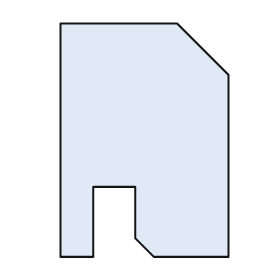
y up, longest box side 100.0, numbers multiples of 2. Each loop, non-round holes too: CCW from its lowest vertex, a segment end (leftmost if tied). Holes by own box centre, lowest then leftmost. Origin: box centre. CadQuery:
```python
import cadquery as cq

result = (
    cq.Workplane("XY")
    .moveTo(-36.0, -50.0)
    .lineTo(-22.0, -50.0)
    .lineTo(-22.0, -20.0)
    .lineTo(-4.0, -20.0)
    .lineTo(-4.0, -42.0)
    .lineTo(4.0, -50.0)
    .lineTo(36.0, -50.0)
    .lineTo(36.0, 28.0)
    .lineTo(14.0, 50.0)
    .lineTo(-36.0, 50.0)
    .close()
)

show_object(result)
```